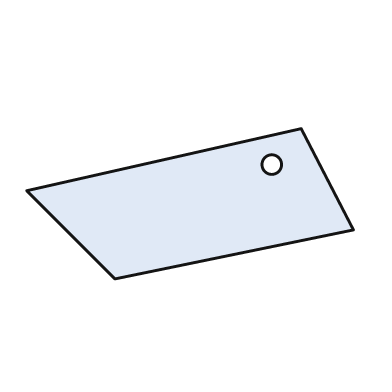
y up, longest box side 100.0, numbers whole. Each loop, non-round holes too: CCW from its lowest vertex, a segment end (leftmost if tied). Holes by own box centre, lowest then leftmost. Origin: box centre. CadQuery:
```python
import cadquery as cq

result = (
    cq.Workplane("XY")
    .moveTo(-23.0, -23.0)
    .lineTo(50.0, -8.0)
    .lineTo(34.0, 23.0)
    .lineTo(-50.0, 4.0)
    .close()
    .moveTo(25.0, 12.0)
    .circle(3.0)
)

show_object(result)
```